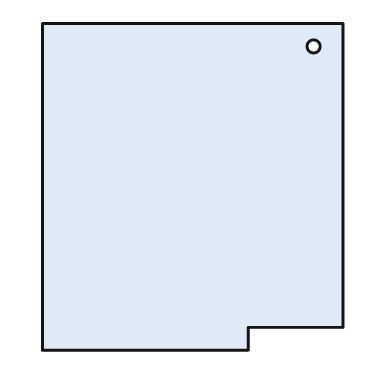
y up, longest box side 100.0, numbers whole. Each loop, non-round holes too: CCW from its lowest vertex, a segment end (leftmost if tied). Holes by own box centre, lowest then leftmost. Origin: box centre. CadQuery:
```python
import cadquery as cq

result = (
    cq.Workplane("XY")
    .moveTo(-46.0, -50.0)
    .lineTo(17.0, -50.0)
    .lineTo(17.0, -43.0)
    .lineTo(46.0, -43.0)
    .lineTo(46.0, 50.0)
    .lineTo(-46.0, 50.0)
    .close()
    .moveTo(37.0, 43.0)
    .circle(2.0)
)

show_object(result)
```